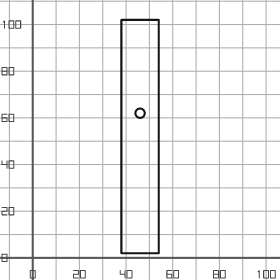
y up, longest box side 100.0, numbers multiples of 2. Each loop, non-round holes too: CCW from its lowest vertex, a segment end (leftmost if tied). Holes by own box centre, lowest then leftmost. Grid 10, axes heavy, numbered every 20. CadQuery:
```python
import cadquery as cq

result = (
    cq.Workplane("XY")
    .moveTo(38.0, 2.0)
    .lineTo(54.0, 2.0)
    .lineTo(54.0, 102.0)
    .lineTo(38.0, 102.0)
    .close()
    .moveTo(46.0, 62.0)
    .circle(2.0)
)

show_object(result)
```